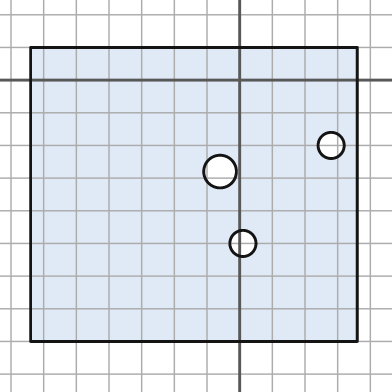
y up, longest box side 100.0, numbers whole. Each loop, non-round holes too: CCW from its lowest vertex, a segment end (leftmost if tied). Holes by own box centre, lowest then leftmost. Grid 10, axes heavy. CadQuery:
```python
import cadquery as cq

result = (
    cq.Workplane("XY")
    .moveTo(-64.0, -80.0)
    .lineTo(36.0, -80.0)
    .lineTo(36.0, 10.0)
    .lineTo(-64.0, 10.0)
    .close()
    .moveTo(1.0, -50.0)
    .circle(4.0)
    .moveTo(-6.0, -28.0)
    .circle(5.0)
    .moveTo(28.0, -20.0)
    .circle(4.0)
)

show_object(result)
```